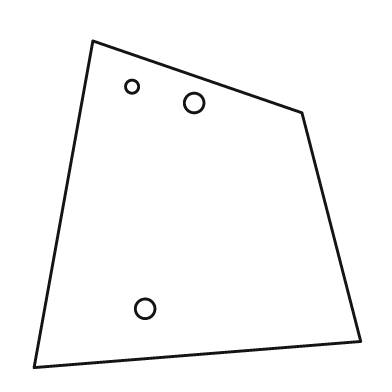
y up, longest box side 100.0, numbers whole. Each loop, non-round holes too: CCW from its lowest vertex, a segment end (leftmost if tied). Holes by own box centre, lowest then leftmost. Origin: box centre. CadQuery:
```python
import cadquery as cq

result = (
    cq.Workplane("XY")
    .moveTo(-50.0, -50.0)
    .lineTo(50.0, -42.0)
    .lineTo(32.0, 28.0)
    .lineTo(-32.0, 50.0)
    .close()
    .moveTo(-16.0, -32.0)
    .circle(3.0)
    .moveTo(-1.0, 31.0)
    .circle(3.0)
    .moveTo(-20.0, 36.0)
    .circle(2.0)
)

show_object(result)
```